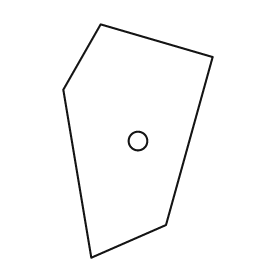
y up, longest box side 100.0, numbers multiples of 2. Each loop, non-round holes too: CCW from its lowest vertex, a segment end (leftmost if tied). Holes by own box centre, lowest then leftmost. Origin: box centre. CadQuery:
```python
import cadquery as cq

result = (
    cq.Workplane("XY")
    .moveTo(-20.0, -50.0)
    .lineTo(12.0, -36.0)
    .lineTo(32.0, 36.0)
    .lineTo(-16.0, 50.0)
    .lineTo(-32.0, 22.0)
    .close()
    .moveTo(0.0, 0.0)
    .circle(4.0)
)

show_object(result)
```